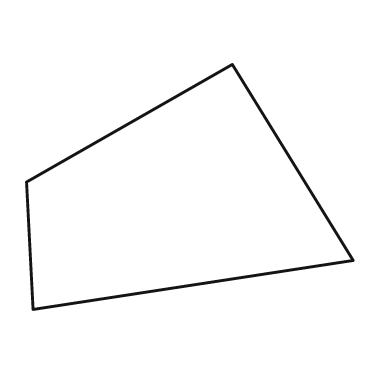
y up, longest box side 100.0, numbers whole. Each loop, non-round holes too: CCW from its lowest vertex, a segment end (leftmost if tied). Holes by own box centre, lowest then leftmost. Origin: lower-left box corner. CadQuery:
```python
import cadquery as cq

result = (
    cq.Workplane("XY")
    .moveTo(2.0, 0.0)
    .lineTo(100.0, 15.0)
    .lineTo(63.0, 75.0)
    .lineTo(0.0, 39.0)
    .close()
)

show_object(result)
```